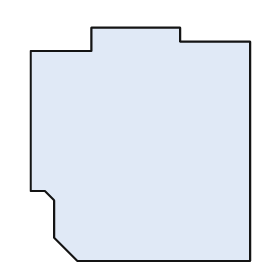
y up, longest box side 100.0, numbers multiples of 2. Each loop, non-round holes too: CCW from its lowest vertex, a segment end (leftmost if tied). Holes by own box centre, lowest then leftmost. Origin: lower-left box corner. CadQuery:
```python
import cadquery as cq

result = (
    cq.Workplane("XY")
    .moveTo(20.0, 0.0)
    .lineTo(94.0, 0.0)
    .lineTo(94.0, 94.0)
    .lineTo(64.0, 94.0)
    .lineTo(64.0, 100.0)
    .lineTo(26.0, 100.0)
    .lineTo(26.0, 90.0)
    .lineTo(0.0, 90.0)
    .lineTo(0.0, 30.0)
    .lineTo(6.0, 30.0)
    .lineTo(10.0, 26.0)
    .lineTo(10.0, 10.0)
    .close()
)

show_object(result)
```